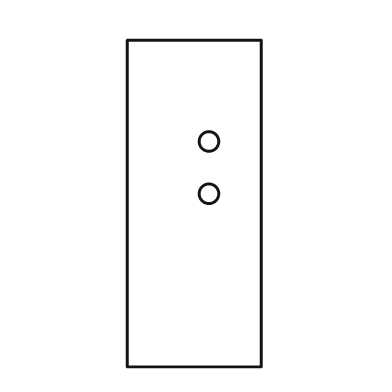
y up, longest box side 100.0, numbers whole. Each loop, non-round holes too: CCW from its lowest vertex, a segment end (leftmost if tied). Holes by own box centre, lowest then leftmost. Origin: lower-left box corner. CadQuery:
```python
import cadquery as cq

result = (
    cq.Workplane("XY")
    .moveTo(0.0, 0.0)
    .lineTo(41.0, 0.0)
    .lineTo(41.0, 100.0)
    .lineTo(0.0, 100.0)
    .close()
    .moveTo(25.0, 53.0)
    .circle(3.0)
    .moveTo(25.0, 69.0)
    .circle(3.0)
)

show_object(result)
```